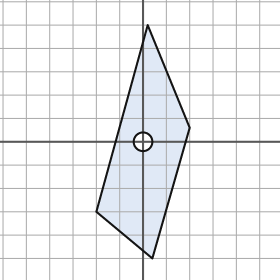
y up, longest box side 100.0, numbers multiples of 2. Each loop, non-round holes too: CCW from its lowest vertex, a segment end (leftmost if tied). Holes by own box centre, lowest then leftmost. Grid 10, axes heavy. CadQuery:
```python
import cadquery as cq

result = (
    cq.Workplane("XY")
    .moveTo(4.0, -50.0)
    .lineTo(20.0, 6.0)
    .lineTo(2.0, 50.0)
    .lineTo(-20.0, -30.0)
    .close()
    .moveTo(0.0, 0.0)
    .circle(4.0)
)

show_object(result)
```